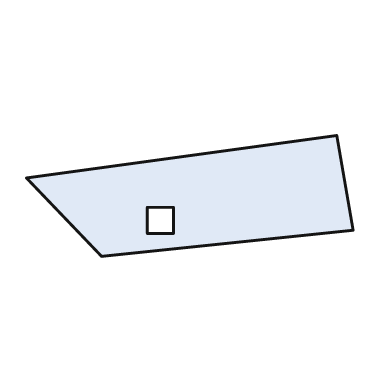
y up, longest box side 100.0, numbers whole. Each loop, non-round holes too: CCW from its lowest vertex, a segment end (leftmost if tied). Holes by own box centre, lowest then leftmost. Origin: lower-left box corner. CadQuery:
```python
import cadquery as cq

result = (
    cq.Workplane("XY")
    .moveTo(23.0, 0.0)
    .lineTo(100.0, 8.0)
    .lineTo(95.0, 37.0)
    .lineTo(0.0, 24.0)
    .close()
    .moveTo(37.0, 7.0)
    .lineTo(45.0, 7.0)
    .lineTo(45.0, 15.0)
    .lineTo(37.0, 15.0)
    .close()
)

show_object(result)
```